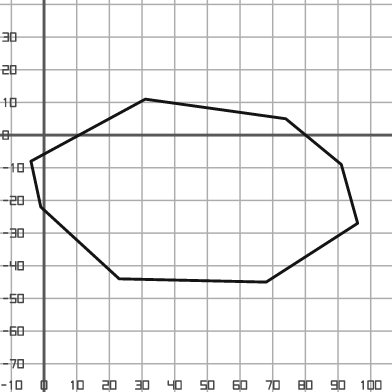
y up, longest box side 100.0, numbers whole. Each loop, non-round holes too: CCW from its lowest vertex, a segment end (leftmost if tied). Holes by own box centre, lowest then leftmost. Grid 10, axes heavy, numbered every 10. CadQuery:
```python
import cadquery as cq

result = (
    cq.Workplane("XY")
    .moveTo(68.0, -45.0)
    .lineTo(96.0, -27.0)
    .lineTo(91.0, -9.0)
    .lineTo(74.0, 5.0)
    .lineTo(31.0, 11.0)
    .lineTo(-4.0, -8.0)
    .lineTo(-1.0, -22.0)
    .lineTo(23.0, -44.0)
    .close()
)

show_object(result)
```